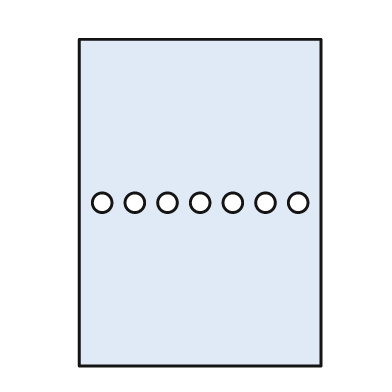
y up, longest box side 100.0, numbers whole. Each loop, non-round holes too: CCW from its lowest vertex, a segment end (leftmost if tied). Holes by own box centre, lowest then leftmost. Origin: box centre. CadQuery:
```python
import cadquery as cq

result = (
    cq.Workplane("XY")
    .moveTo(-37.0, -50.0)
    .lineTo(37.0, -50.0)
    .lineTo(37.0, 50.0)
    .lineTo(-37.0, 50.0)
    .close()
    .moveTo(-30.0, 0.0)
    .circle(3.0)
    .moveTo(-20.0, 0.0)
    .circle(3.0)
    .moveTo(-10.0, 0.0)
    .circle(3.0)
    .moveTo(0.0, 0.0)
    .circle(3.0)
    .moveTo(10.0, 0.0)
    .circle(3.0)
    .moveTo(20.0, 0.0)
    .circle(3.0)
    .moveTo(30.0, 0.0)
    .circle(3.0)
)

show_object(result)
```